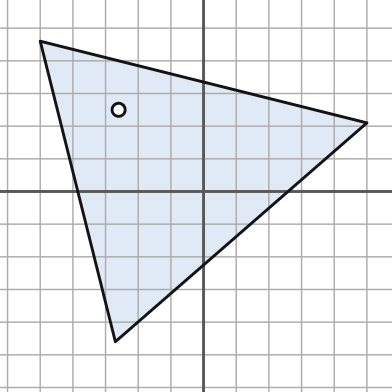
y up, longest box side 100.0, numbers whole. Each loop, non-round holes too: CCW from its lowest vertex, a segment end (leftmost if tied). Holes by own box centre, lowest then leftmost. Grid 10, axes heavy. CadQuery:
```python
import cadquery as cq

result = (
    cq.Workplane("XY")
    .moveTo(-27.0, -46.0)
    .lineTo(50.0, 21.0)
    .lineTo(-50.0, 46.0)
    .close()
    .moveTo(-26.0, 25.0)
    .circle(2.0)
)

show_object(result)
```